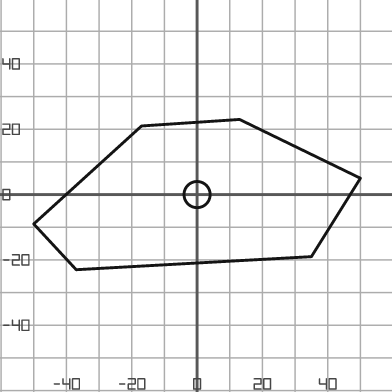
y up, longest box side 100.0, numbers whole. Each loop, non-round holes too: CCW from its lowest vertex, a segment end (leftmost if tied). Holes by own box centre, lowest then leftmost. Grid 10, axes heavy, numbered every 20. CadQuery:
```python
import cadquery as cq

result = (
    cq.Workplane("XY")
    .moveTo(-37.0, -23.0)
    .lineTo(35.0, -19.0)
    .lineTo(50.0, 5.0)
    .lineTo(13.0, 23.0)
    .lineTo(-17.0, 21.0)
    .lineTo(-50.0, -9.0)
    .close()
    .moveTo(0.0, 0.0)
    .circle(4.0)
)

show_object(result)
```